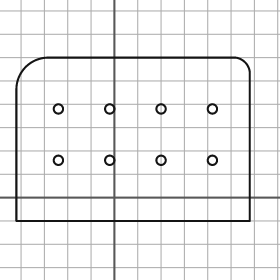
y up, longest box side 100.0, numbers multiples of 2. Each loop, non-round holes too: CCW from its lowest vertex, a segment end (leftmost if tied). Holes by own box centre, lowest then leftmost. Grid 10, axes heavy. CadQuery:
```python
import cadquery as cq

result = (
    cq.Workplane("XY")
    .moveTo(-42.0, -10.0)
    .lineTo(58.0, -10.0)
    .lineTo(58.0, 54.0)
    .threePointArc((56.0, 58.0), (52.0, 60.0))
    .lineTo(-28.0, 60.0)
    .threePointArc((-38.0, 56.0), (-42.0, 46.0))
    .close()
    .moveTo(-24.0, 16.0)
    .circle(2.0)
    .moveTo(-2.0, 16.0)
    .circle(2.0)
    .moveTo(20.0, 16.0)
    .circle(2.0)
    .moveTo(42.0, 16.0)
    .circle(2.0)
    .moveTo(-24.0, 38.0)
    .circle(2.0)
    .moveTo(-2.0, 38.0)
    .circle(2.0)
    .moveTo(20.0, 38.0)
    .circle(2.0)
    .moveTo(42.0, 38.0)
    .circle(2.0)
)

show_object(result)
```